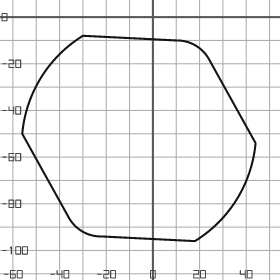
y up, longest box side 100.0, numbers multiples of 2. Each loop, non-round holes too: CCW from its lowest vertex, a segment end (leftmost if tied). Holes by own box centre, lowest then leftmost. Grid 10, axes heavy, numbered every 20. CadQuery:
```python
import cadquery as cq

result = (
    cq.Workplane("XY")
    .moveTo(18.0, -96.0)
    .threePointArc((36.0, -78.0), (44.0, -54.0))
    .lineTo(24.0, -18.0)
    .threePointArc((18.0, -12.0), (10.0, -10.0))
    .lineTo(-30.0, -8.0)
    .threePointArc((-48.0, -26.0), (-56.0, -50.0))
    .lineTo(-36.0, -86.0)
    .threePointArc((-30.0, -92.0), (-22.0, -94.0))
    .close()
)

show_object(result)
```